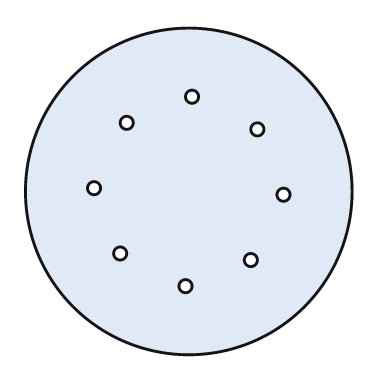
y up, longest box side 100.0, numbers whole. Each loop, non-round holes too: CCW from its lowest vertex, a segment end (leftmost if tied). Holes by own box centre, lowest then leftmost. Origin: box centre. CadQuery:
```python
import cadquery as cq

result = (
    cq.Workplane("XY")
    .moveTo(0.0, 0.0)
    .circle(50.0)
    .moveTo(-1.0, -29.0)
    .circle(2.0)
    .moveTo(19.0, -21.0)
    .circle(2.0)
    .moveTo(-21.0, -19.0)
    .circle(2.0)
    .moveTo(29.0, -1.0)
    .circle(2.0)
    .moveTo(-29.0, 1.0)
    .circle(2.0)
    .moveTo(21.0, 19.0)
    .circle(2.0)
    .moveTo(-19.0, 21.0)
    .circle(2.0)
    .moveTo(1.0, 29.0)
    .circle(2.0)
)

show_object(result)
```